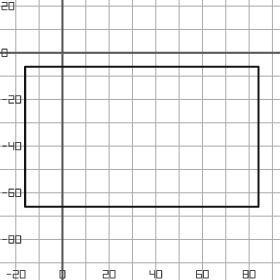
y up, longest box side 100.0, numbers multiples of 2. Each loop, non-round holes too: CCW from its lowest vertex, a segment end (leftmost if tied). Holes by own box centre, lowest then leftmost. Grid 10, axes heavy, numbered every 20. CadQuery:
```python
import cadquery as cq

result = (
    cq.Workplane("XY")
    .moveTo(-16.0, -66.0)
    .lineTo(84.0, -66.0)
    .lineTo(84.0, -6.0)
    .lineTo(-16.0, -6.0)
    .close()
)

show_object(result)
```